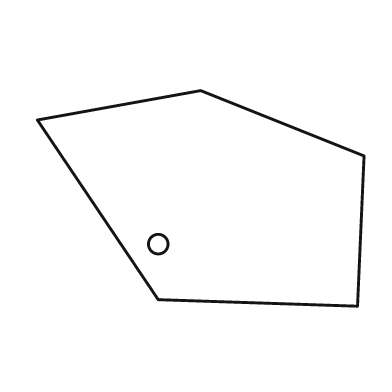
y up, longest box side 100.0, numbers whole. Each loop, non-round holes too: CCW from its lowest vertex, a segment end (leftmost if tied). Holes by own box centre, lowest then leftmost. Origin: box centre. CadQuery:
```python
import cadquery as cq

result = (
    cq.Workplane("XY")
    .moveTo(48.0, -33.0)
    .lineTo(50.0, 13.0)
    .lineTo(0.0, 33.0)
    .lineTo(-50.0, 24.0)
    .lineTo(-13.0, -31.0)
    .close()
    .moveTo(-13.0, -14.0)
    .circle(3.0)
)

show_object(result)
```